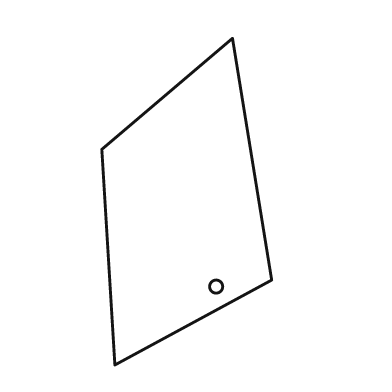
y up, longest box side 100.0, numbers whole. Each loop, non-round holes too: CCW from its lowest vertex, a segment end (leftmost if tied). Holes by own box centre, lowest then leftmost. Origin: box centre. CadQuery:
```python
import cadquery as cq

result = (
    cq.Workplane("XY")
    .moveTo(-22.0, -50.0)
    .lineTo(26.0, -24.0)
    .lineTo(14.0, 50.0)
    .lineTo(-26.0, 16.0)
    .close()
    .moveTo(9.0, -26.0)
    .circle(2.0)
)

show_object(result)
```